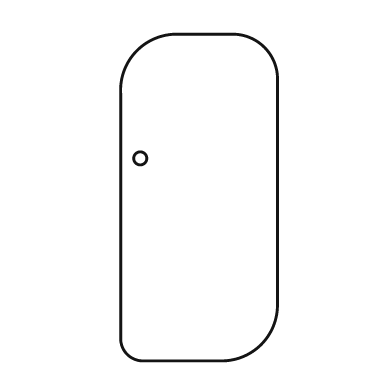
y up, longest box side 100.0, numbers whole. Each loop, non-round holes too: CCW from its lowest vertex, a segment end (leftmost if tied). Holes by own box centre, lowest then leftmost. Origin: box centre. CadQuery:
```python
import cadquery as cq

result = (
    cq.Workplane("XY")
    .moveTo(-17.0, -50.0)
    .lineTo(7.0, -50.0)
    .threePointArc((19.0, -45.0), (24.0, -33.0))
    .lineTo(24.0, 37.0)
    .threePointArc((20.0, 46.0), (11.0, 50.0))
    .lineTo(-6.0, 50.0)
    .threePointArc((-19.0, 45.0), (-24.0, 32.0))
    .lineTo(-24.0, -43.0)
    .threePointArc((-22.0, -48.0), (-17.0, -50.0))
    .close()
    .moveTo(-18.0, 12.0)
    .circle(2.0)
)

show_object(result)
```